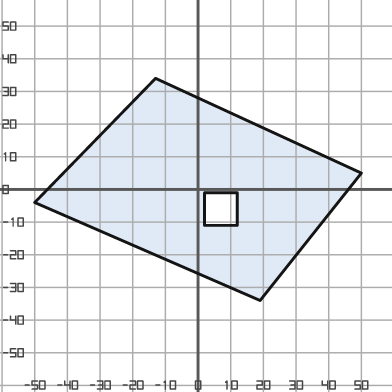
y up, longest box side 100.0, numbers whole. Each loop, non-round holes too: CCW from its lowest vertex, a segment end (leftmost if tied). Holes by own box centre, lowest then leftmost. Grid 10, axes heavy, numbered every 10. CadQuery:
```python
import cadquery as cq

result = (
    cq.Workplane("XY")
    .moveTo(19.0, -34.0)
    .lineTo(50.0, 5.0)
    .lineTo(-13.0, 34.0)
    .lineTo(-50.0, -4.0)
    .close()
    .moveTo(2.0, -11.0)
    .lineTo(12.0, -11.0)
    .lineTo(12.0, -1.0)
    .lineTo(2.0, -1.0)
    .close()
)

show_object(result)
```